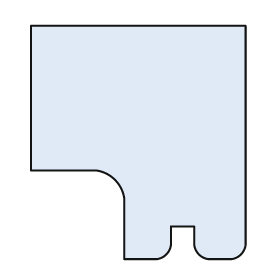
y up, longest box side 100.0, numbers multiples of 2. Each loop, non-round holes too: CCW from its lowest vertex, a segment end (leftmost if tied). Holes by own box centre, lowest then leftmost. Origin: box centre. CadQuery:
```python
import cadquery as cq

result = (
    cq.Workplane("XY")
    .moveTo(-6.0, -50.0)
    .lineTo(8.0, -50.0)
    .threePointArc((12.0, -48.0), (14.0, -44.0))
    .lineTo(14.0, -36.0)
    .lineTo(24.0, -36.0)
    .lineTo(24.0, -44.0)
    .threePointArc((26.0, -48.0), (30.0, -50.0))
    .lineTo(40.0, -50.0)
    .threePointArc((44.0, -48.0), (46.0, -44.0))
    .lineTo(46.0, 50.0)
    .lineTo(-46.0, 50.0)
    .lineTo(-46.0, -12.0)
    .lineTo(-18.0, -12.0)
    .threePointArc((-10.0, -16.0), (-6.0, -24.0))
    .close()
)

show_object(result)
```